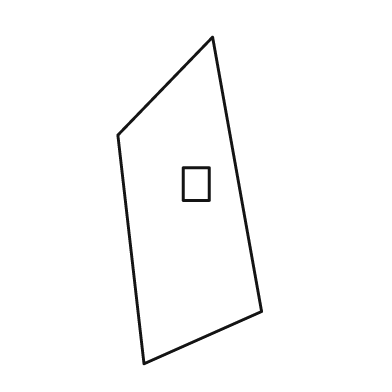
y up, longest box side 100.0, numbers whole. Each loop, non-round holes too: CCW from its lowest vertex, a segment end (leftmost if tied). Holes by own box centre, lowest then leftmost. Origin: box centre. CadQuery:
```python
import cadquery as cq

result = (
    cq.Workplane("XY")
    .moveTo(-14.0, -50.0)
    .lineTo(22.0, -34.0)
    .lineTo(7.0, 50.0)
    .lineTo(-22.0, 20.0)
    .close()
    .moveTo(-2.0, 0.0)
    .lineTo(6.0, 0.0)
    .lineTo(6.0, 10.0)
    .lineTo(-2.0, 10.0)
    .close()
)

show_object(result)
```